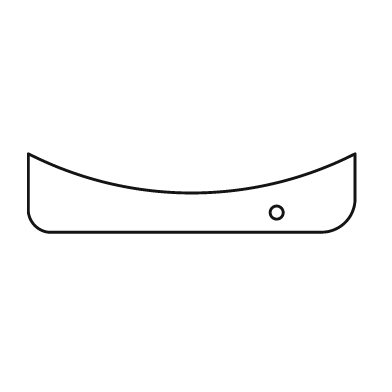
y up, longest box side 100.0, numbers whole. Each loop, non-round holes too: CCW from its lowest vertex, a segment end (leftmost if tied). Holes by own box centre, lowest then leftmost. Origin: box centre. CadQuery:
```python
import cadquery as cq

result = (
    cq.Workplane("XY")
    .moveTo(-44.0, -12.0)
    .lineTo(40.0, -12.0)
    .threePointArc((47.0, -9.0), (50.0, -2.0))
    .lineTo(50.0, 12.0)
    .threePointArc((0.0, 0.0), (-50.0, 12.0))
    .lineTo(-50.0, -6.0)
    .threePointArc((-48.0, -10.0), (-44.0, -12.0))
    .close()
    .moveTo(26.0, -6.0)
    .circle(2.0)
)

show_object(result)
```